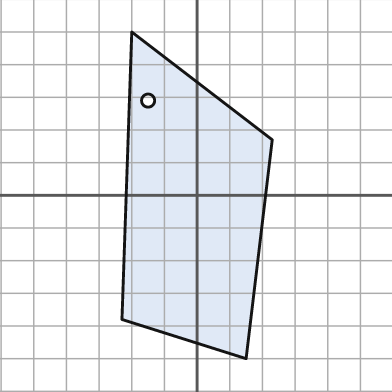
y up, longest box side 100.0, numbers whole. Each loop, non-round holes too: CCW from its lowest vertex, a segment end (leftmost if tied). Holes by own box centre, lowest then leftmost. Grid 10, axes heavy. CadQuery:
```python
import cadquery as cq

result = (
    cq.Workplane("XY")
    .moveTo(15.0, -50.0)
    .lineTo(23.0, 17.0)
    .lineTo(-20.0, 50.0)
    .lineTo(-23.0, -38.0)
    .close()
    .moveTo(-15.0, 29.0)
    .circle(2.0)
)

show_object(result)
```